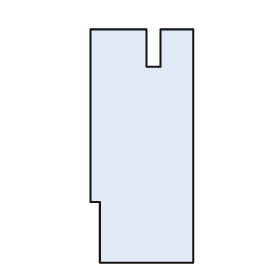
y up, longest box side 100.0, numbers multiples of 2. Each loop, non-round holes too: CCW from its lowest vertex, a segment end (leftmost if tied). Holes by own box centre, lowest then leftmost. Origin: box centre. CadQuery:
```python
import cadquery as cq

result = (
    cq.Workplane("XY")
    .moveTo(-18.0, -50.0)
    .lineTo(22.0, -50.0)
    .lineTo(22.0, 50.0)
    .lineTo(8.0, 50.0)
    .lineTo(8.0, 34.0)
    .lineTo(2.0, 34.0)
    .lineTo(2.0, 50.0)
    .lineTo(-22.0, 50.0)
    .lineTo(-22.0, -24.0)
    .lineTo(-18.0, -24.0)
    .close()
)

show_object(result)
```